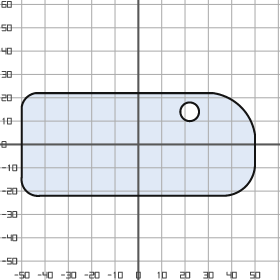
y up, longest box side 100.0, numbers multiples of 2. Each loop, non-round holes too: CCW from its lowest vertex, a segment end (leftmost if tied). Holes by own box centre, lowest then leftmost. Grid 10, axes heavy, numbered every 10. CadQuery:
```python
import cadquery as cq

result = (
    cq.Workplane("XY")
    .moveTo(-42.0, -22.0)
    .lineTo(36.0, -22.0)
    .threePointArc((46.0, -18.0), (50.0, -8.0))
    .lineTo(50.0, 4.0)
    .threePointArc((44.0, 16.0), (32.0, 22.0))
    .lineTo(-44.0, 22.0)
    .threePointArc((-48.0, 20.0), (-50.0, 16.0))
    .lineTo(-50.0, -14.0)
    .threePointArc((-48.0, -20.0), (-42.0, -22.0))
    .close()
    .moveTo(22.0, 14.0)
    .circle(4.0)
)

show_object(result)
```